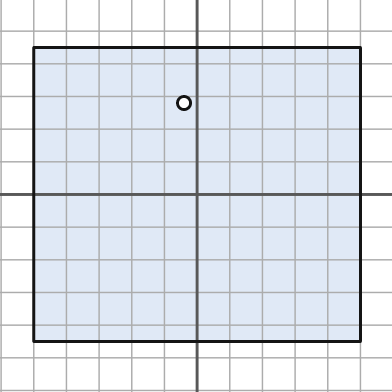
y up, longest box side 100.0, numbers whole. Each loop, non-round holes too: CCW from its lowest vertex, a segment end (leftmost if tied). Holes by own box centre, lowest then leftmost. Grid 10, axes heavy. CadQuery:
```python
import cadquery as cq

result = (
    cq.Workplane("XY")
    .moveTo(-50.0, -45.0)
    .lineTo(50.0, -45.0)
    .lineTo(50.0, 45.0)
    .lineTo(-50.0, 45.0)
    .close()
    .moveTo(-4.0, 28.0)
    .circle(2.0)
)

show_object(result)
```